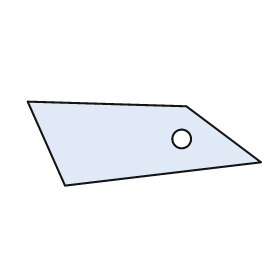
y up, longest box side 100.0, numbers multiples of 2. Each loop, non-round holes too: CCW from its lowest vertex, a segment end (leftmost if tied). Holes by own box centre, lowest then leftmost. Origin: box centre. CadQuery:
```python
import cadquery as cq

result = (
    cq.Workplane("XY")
    .moveTo(-34.0, -18.0)
    .lineTo(50.0, -8.0)
    .lineTo(18.0, 16.0)
    .lineTo(-50.0, 18.0)
    .close()
    .moveTo(16.0, 2.0)
    .circle(4.0)
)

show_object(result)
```